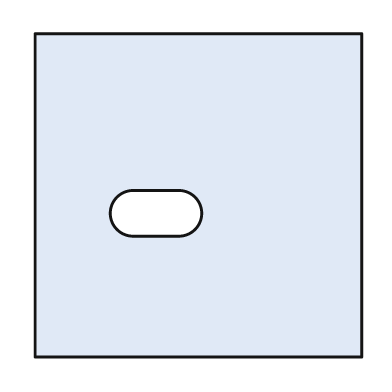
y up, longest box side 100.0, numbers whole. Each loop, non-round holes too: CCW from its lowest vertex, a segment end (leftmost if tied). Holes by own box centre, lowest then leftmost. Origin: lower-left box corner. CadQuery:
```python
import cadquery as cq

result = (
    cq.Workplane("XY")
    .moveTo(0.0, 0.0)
    .lineTo(100.0, 0.0)
    .lineTo(100.0, 99.0)
    .lineTo(0.0, 99.0)
    .close()
    .moveTo(30.0, 37.0)
    .lineTo(44.0, 37.0)
    .threePointArc((51.0, 44.0), (44.0, 51.0))
    .lineTo(30.0, 51.0)
    .threePointArc((23.0, 44.0), (30.0, 37.0))
    .close()
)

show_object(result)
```